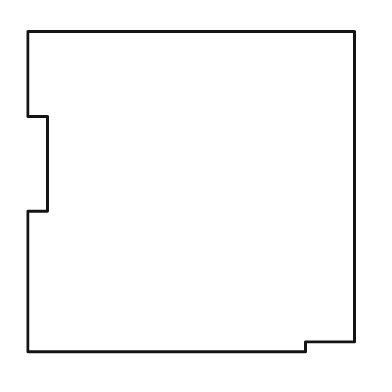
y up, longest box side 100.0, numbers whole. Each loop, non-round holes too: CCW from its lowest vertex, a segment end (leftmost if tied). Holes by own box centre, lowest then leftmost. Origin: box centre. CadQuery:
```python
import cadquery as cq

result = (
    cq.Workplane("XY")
    .moveTo(-50.0, -49.0)
    .lineTo(35.0, -49.0)
    .lineTo(35.0, -46.0)
    .lineTo(50.0, -46.0)
    .lineTo(50.0, 49.0)
    .lineTo(-50.0, 49.0)
    .lineTo(-50.0, 23.0)
    .lineTo(-44.0, 23.0)
    .lineTo(-44.0, -6.0)
    .lineTo(-50.0, -6.0)
    .close()
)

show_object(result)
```